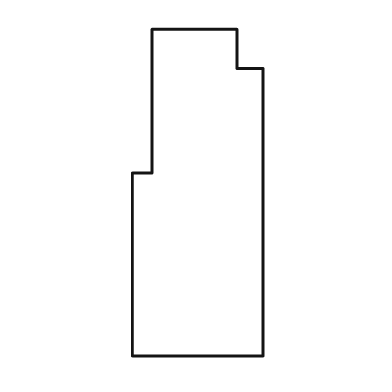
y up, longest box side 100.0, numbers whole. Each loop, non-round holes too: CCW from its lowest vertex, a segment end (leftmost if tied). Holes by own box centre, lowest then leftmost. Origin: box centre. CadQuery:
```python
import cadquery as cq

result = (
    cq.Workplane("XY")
    .moveTo(-20.0, -50.0)
    .lineTo(20.0, -50.0)
    .lineTo(20.0, 38.0)
    .lineTo(12.0, 38.0)
    .lineTo(12.0, 50.0)
    .lineTo(-14.0, 50.0)
    .lineTo(-14.0, 6.0)
    .lineTo(-20.0, 6.0)
    .close()
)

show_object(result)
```